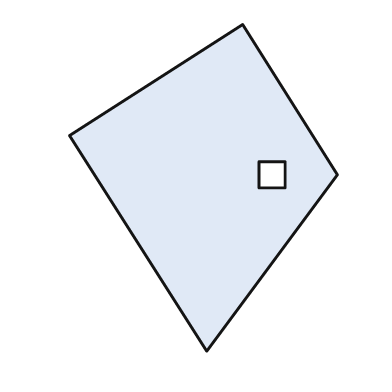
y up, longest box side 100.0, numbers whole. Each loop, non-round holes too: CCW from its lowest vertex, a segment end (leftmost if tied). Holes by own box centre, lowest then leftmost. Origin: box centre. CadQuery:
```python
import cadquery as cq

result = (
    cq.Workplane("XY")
    .moveTo(1.0, -50.0)
    .lineTo(41.0, 4.0)
    .lineTo(12.0, 50.0)
    .lineTo(-41.0, 16.0)
    .close()
    .moveTo(17.0, 0.0)
    .lineTo(25.0, 0.0)
    .lineTo(25.0, 8.0)
    .lineTo(17.0, 8.0)
    .close()
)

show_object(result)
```